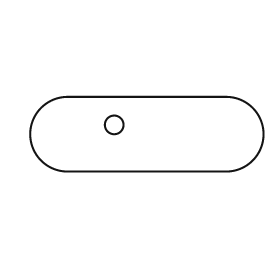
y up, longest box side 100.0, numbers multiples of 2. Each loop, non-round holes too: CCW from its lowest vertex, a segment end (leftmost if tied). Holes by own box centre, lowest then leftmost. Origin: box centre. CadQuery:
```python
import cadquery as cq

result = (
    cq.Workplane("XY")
    .moveTo(-34.0, -16.0)
    .lineTo(34.0, -16.0)
    .threePointArc((50.0, 0.0), (34.0, 16.0))
    .lineTo(-34.0, 16.0)
    .threePointArc((-50.0, 0.0), (-34.0, -16.0))
    .close()
    .moveTo(-14.0, 4.0)
    .circle(4.0)
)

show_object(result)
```